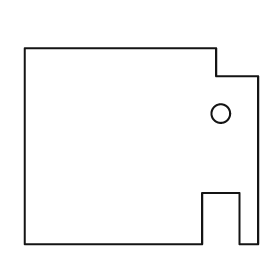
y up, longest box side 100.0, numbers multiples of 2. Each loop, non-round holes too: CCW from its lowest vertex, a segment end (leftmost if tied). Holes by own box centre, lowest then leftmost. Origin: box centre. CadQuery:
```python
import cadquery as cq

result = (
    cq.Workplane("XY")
    .moveTo(-50.0, -42.0)
    .lineTo(26.0, -42.0)
    .lineTo(26.0, -20.0)
    .lineTo(42.0, -20.0)
    .lineTo(42.0, -42.0)
    .lineTo(50.0, -42.0)
    .lineTo(50.0, 30.0)
    .lineTo(32.0, 30.0)
    .lineTo(32.0, 42.0)
    .lineTo(-50.0, 42.0)
    .close()
    .moveTo(34.0, 14.0)
    .circle(4.0)
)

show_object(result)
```